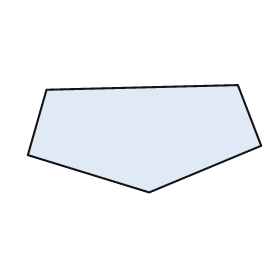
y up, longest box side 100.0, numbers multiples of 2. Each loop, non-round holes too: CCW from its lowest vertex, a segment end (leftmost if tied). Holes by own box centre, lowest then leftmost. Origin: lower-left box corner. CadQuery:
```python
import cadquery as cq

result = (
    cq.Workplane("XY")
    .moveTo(52.0, 0.0)
    .lineTo(100.0, 20.0)
    .lineTo(90.0, 46.0)
    .lineTo(8.0, 44.0)
    .lineTo(0.0, 16.0)
    .close()
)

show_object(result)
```